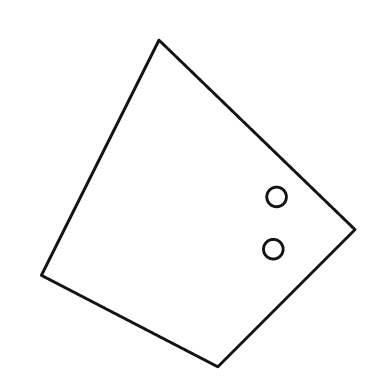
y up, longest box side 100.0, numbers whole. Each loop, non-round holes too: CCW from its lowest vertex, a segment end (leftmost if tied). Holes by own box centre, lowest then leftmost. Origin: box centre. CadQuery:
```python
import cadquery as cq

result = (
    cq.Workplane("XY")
    .moveTo(6.0, -50.0)
    .lineTo(48.0, -8.0)
    .lineTo(-12.0, 50.0)
    .lineTo(-48.0, -22.0)
    .close()
    .moveTo(23.0, -14.0)
    .circle(3.0)
    .moveTo(24.0, 2.0)
    .circle(3.0)
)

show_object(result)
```